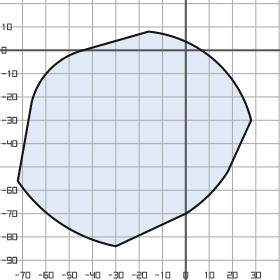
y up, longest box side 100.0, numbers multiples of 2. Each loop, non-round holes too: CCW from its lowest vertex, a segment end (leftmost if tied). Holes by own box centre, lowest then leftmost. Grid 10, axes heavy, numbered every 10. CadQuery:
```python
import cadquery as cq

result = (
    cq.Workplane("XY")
    .moveTo(-30.0, -84.0)
    .lineTo(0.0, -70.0)
    .threePointArc((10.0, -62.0), (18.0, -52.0))
    .lineTo(28.0, -30.0)
    .threePointArc((12.0, -4.0), (-16.0, 8.0))
    .lineTo(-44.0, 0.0)
    .threePointArc((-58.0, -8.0), (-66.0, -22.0))
    .lineTo(-72.0, -56.0)
    .threePointArc((-54.0, -74.0), (-30.0, -84.0))
    .close()
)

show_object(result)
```